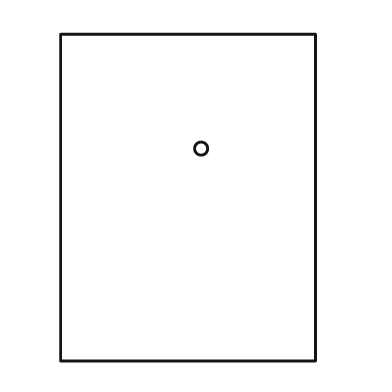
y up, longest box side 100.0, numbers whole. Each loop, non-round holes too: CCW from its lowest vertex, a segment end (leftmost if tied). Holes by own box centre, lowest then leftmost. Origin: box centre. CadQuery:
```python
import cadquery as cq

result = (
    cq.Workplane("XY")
    .moveTo(-39.0, -50.0)
    .lineTo(39.0, -50.0)
    .lineTo(39.0, 50.0)
    .lineTo(-39.0, 50.0)
    .close()
    .moveTo(4.0, 15.0)
    .circle(2.0)
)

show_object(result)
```